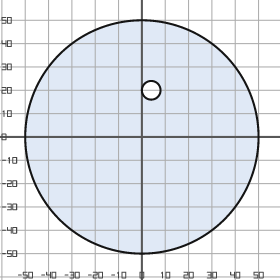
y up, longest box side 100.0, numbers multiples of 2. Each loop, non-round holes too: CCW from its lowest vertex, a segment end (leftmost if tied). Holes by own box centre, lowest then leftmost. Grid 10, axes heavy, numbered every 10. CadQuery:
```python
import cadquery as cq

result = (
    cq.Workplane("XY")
    .moveTo(0.0, 0.0)
    .circle(50.0)
    .moveTo(4.0, 20.0)
    .circle(4.0)
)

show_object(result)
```